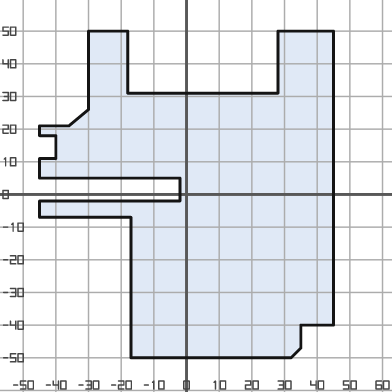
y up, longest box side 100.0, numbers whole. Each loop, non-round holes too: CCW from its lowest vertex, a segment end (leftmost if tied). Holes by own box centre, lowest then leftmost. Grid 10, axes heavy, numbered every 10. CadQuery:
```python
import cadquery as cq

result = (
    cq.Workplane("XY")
    .moveTo(-17.0, -50.0)
    .lineTo(32.0, -50.0)
    .lineTo(35.0, -47.0)
    .lineTo(35.0, -40.0)
    .lineTo(45.0, -40.0)
    .lineTo(45.0, 50.0)
    .lineTo(28.0, 50.0)
    .lineTo(28.0, 31.0)
    .lineTo(-18.0, 31.0)
    .lineTo(-18.0, 50.0)
    .lineTo(-30.0, 50.0)
    .lineTo(-30.0, 26.0)
    .lineTo(-36.0, 21.0)
    .lineTo(-45.0, 21.0)
    .lineTo(-45.0, 18.0)
    .lineTo(-40.0, 18.0)
    .lineTo(-40.0, 11.0)
    .lineTo(-45.0, 11.0)
    .lineTo(-45.0, 5.0)
    .lineTo(-2.0, 5.0)
    .lineTo(-2.0, -2.0)
    .lineTo(-45.0, -2.0)
    .lineTo(-45.0, -7.0)
    .lineTo(-17.0, -7.0)
    .close()
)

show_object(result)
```